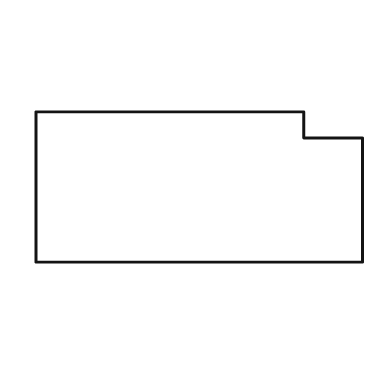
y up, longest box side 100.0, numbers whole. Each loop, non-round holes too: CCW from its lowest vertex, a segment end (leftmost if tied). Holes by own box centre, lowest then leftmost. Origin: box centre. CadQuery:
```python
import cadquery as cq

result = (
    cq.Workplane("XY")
    .moveTo(-50.0, -23.0)
    .lineTo(50.0, -23.0)
    .lineTo(50.0, 15.0)
    .lineTo(32.0, 15.0)
    .lineTo(32.0, 23.0)
    .lineTo(-50.0, 23.0)
    .close()
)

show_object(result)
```